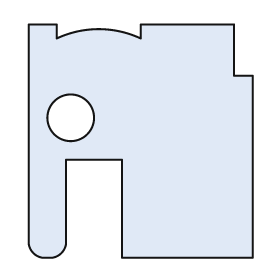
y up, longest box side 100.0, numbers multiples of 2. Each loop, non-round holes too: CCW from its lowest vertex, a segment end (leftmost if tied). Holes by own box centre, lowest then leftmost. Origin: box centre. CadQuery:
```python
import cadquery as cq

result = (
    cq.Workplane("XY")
    .moveTo(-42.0, -50.0)
    .lineTo(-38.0, -50.0)
    .threePointArc((-34.0, -48.0), (-32.0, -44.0))
    .lineTo(-32.0, -8.0)
    .lineTo(-8.0, -8.0)
    .lineTo(-8.0, -50.0)
    .lineTo(48.0, -50.0)
    .lineTo(48.0, 28.0)
    .lineTo(40.0, 28.0)
    .lineTo(40.0, 50.0)
    .lineTo(0.0, 50.0)
    .lineTo(0.0, 44.0)
    .threePointArc((-18.0, 48.0), (-36.0, 44.0))
    .lineTo(-36.0, 50.0)
    .lineTo(-48.0, 50.0)
    .lineTo(-48.0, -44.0)
    .threePointArc((-46.0, -48.0), (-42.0, -50.0))
    .close()
    .moveTo(-30.0, 10.0)
    .circle(10.0)
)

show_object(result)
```